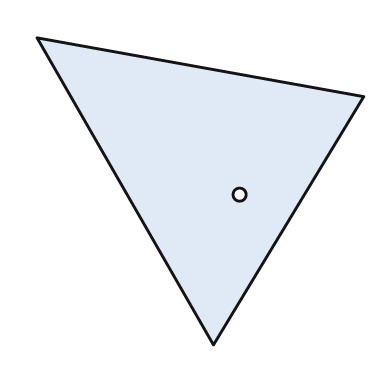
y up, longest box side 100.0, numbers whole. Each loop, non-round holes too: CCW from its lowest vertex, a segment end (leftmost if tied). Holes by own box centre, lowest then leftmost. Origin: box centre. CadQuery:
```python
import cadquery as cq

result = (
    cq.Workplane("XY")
    .moveTo(4.0, -47.0)
    .lineTo(50.0, 29.0)
    .lineTo(-50.0, 47.0)
    .close()
    .moveTo(12.0, -1.0)
    .circle(2.0)
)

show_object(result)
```